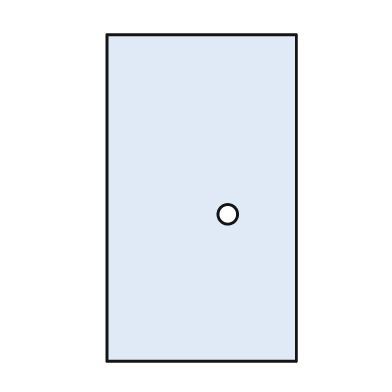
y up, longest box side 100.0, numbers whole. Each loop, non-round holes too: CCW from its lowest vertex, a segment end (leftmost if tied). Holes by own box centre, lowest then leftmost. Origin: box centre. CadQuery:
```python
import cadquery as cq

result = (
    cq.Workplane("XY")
    .moveTo(-29.0, -50.0)
    .lineTo(29.0, -50.0)
    .lineTo(29.0, 50.0)
    .lineTo(-29.0, 50.0)
    .close()
    .moveTo(8.0, -5.0)
    .circle(3.0)
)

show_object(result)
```